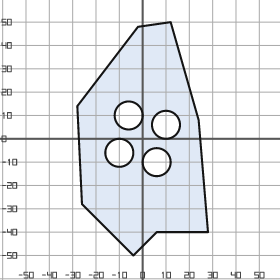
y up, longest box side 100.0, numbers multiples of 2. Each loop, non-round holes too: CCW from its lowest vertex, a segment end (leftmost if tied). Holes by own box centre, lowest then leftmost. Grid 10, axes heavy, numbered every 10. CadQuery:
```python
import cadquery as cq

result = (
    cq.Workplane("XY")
    .moveTo(-4.0, -50.0)
    .lineTo(6.0, -40.0)
    .lineTo(28.0, -40.0)
    .lineTo(24.0, 8.0)
    .lineTo(12.0, 50.0)
    .lineTo(-2.0, 48.0)
    .lineTo(-28.0, 14.0)
    .lineTo(-26.0, -28.0)
    .close()
    .moveTo(6.0, -10.0)
    .circle(6.0)
    .moveTo(-10.0, -6.0)
    .circle(6.0)
    .moveTo(10.0, 6.0)
    .circle(6.0)
    .moveTo(-6.0, 10.0)
    .circle(6.0)
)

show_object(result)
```